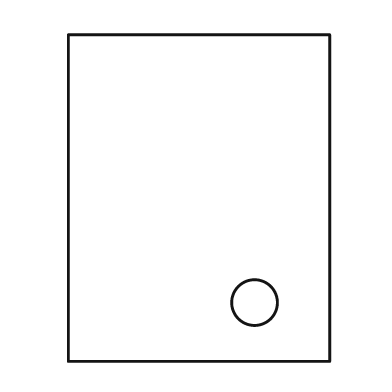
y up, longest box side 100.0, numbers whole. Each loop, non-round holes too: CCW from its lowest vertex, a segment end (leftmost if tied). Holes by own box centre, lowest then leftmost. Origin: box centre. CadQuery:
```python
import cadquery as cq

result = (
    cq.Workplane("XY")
    .moveTo(-40.0, -50.0)
    .lineTo(40.0, -50.0)
    .lineTo(40.0, 50.0)
    .lineTo(-40.0, 50.0)
    .close()
    .moveTo(17.0, -32.0)
    .circle(7.0)
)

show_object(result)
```